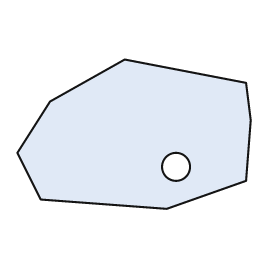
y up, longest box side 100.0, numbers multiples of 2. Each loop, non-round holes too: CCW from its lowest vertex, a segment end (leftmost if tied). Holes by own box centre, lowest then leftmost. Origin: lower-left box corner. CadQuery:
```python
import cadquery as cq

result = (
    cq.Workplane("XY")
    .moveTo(64.0, 0.0)
    .lineTo(98.0, 12.0)
    .lineTo(100.0, 38.0)
    .lineTo(98.0, 54.0)
    .lineTo(46.0, 64.0)
    .lineTo(14.0, 46.0)
    .lineTo(0.0, 24.0)
    .lineTo(10.0, 4.0)
    .close()
    .moveTo(68.0, 18.0)
    .circle(6.0)
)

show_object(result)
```